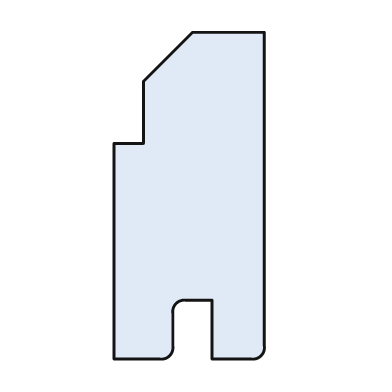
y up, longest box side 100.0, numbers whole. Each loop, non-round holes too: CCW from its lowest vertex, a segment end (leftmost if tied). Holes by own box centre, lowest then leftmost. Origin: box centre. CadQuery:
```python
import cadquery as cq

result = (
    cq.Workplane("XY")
    .moveTo(-23.0, -50.0)
    .lineTo(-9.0, -50.0)
    .threePointArc((-6.0, -49.0), (-5.0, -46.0))
    .lineTo(-5.0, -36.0)
    .threePointArc((-4.0, -33.0), (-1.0, -32.0))
    .lineTo(7.0, -32.0)
    .lineTo(7.0, -50.0)
    .lineTo(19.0, -50.0)
    .threePointArc((22.0, -49.0), (23.0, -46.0))
    .lineTo(23.0, 50.0)
    .lineTo(1.0, 50.0)
    .lineTo(-14.0, 35.0)
    .lineTo(-14.0, 16.0)
    .lineTo(-23.0, 16.0)
    .close()
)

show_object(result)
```